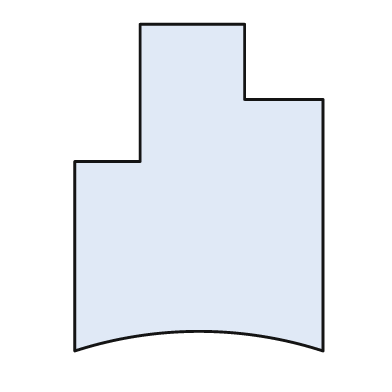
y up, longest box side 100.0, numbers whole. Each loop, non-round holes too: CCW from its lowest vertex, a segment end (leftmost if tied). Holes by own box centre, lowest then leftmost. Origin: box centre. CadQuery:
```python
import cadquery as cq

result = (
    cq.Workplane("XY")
    .moveTo(-38.0, -50.0)
    .threePointArc((0.0, -44.0), (38.0, -50.0))
    .lineTo(38.0, 27.0)
    .lineTo(14.0, 27.0)
    .lineTo(14.0, 50.0)
    .lineTo(-18.0, 50.0)
    .lineTo(-18.0, 8.0)
    .lineTo(-38.0, 8.0)
    .close()
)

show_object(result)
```